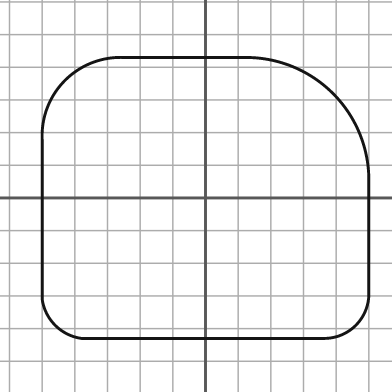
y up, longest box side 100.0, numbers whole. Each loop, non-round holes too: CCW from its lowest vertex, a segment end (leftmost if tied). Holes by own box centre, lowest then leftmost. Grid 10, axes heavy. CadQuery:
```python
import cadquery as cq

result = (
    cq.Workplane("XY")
    .moveTo(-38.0, -43.0)
    .lineTo(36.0, -43.0)
    .threePointArc((46.0, -39.0), (50.0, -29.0))
    .lineTo(50.0, 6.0)
    .threePointArc((39.0, 32.0), (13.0, 43.0))
    .lineTo(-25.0, 43.0)
    .threePointArc((-43.0, 36.0), (-50.0, 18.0))
    .lineTo(-50.0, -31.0)
    .threePointArc((-46.0, -39.0), (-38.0, -43.0))
    .close()
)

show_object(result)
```